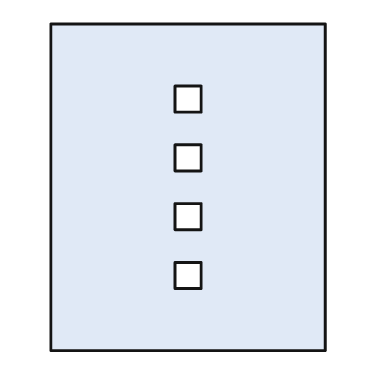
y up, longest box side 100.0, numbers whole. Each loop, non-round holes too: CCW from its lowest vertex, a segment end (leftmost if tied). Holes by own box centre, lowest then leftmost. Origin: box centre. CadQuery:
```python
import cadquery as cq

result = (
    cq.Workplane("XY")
    .moveTo(-42.0, -50.0)
    .lineTo(42.0, -50.0)
    .lineTo(42.0, 50.0)
    .lineTo(-42.0, 50.0)
    .close()
    .moveTo(-4.0, -31.0)
    .lineTo(4.0, -31.0)
    .lineTo(4.0, -23.0)
    .lineTo(-4.0, -23.0)
    .close()
    .moveTo(-4.0, -13.0)
    .lineTo(4.0, -13.0)
    .lineTo(4.0, -5.0)
    .lineTo(-4.0, -5.0)
    .close()
    .moveTo(-4.0, 5.0)
    .lineTo(4.0, 5.0)
    .lineTo(4.0, 13.0)
    .lineTo(-4.0, 13.0)
    .close()
    .moveTo(-4.0, 23.0)
    .lineTo(4.0, 23.0)
    .lineTo(4.0, 31.0)
    .lineTo(-4.0, 31.0)
    .close()
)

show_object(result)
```